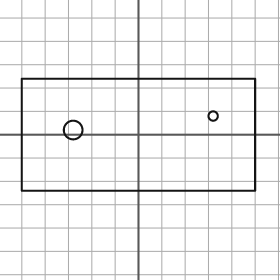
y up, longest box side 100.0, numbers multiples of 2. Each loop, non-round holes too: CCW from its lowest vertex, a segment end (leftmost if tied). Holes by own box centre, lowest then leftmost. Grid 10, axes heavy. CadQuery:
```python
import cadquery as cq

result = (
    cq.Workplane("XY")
    .moveTo(-50.0, -24.0)
    .lineTo(50.0, -24.0)
    .lineTo(50.0, 24.0)
    .lineTo(-50.0, 24.0)
    .close()
    .moveTo(-28.0, 2.0)
    .circle(4.0)
    .moveTo(32.0, 8.0)
    .circle(2.0)
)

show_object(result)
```